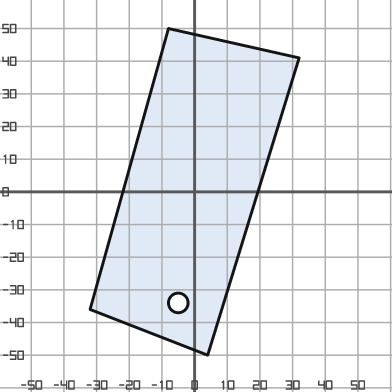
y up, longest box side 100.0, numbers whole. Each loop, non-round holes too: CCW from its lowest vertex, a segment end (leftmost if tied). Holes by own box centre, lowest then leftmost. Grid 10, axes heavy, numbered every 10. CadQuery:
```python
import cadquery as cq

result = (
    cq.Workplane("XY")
    .moveTo(4.0, -50.0)
    .lineTo(32.0, 41.0)
    .lineTo(-8.0, 50.0)
    .lineTo(-32.0, -36.0)
    .close()
    .moveTo(-5.0, -34.0)
    .circle(3.0)
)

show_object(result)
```